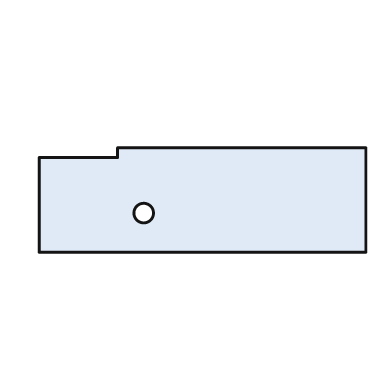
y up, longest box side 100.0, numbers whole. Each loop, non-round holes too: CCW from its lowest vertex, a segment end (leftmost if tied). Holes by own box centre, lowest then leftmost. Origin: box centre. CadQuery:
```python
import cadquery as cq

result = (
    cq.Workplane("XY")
    .moveTo(-50.0, -16.0)
    .lineTo(50.0, -16.0)
    .lineTo(50.0, 16.0)
    .lineTo(-26.0, 16.0)
    .lineTo(-26.0, 13.0)
    .lineTo(-50.0, 13.0)
    .close()
    .moveTo(-18.0, -4.0)
    .circle(3.0)
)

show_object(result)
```